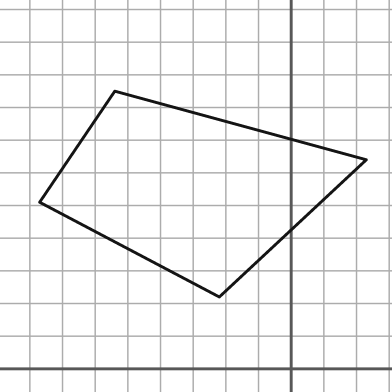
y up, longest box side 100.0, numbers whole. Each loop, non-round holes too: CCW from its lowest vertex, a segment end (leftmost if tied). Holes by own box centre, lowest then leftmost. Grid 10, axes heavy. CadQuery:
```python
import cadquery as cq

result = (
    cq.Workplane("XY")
    .moveTo(-22.0, 22.0)
    .lineTo(23.0, 64.0)
    .lineTo(-54.0, 85.0)
    .lineTo(-77.0, 51.0)
    .close()
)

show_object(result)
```